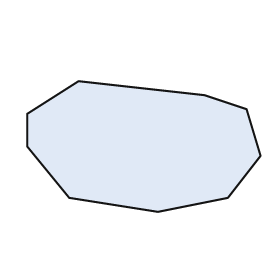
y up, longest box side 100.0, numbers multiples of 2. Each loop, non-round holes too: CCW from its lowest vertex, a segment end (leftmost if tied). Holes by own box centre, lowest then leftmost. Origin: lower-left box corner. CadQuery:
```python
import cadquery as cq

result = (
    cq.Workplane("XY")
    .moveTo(56.0, 0.0)
    .lineTo(86.0, 6.0)
    .lineTo(100.0, 24.0)
    .lineTo(94.0, 44.0)
    .lineTo(76.0, 50.0)
    .lineTo(22.0, 56.0)
    .lineTo(0.0, 42.0)
    .lineTo(0.0, 28.0)
    .lineTo(18.0, 6.0)
    .close()
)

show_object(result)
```